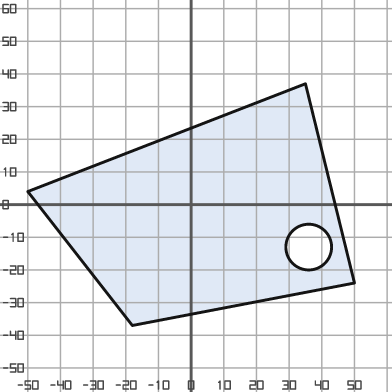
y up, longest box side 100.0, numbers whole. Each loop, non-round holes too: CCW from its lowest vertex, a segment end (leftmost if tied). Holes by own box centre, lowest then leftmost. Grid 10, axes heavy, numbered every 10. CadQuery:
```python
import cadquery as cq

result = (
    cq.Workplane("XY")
    .moveTo(-18.0, -37.0)
    .lineTo(50.0, -24.0)
    .lineTo(35.0, 37.0)
    .lineTo(-50.0, 4.0)
    .close()
    .moveTo(36.0, -13.0)
    .circle(7.0)
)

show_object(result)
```